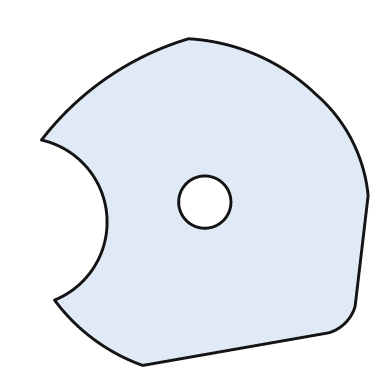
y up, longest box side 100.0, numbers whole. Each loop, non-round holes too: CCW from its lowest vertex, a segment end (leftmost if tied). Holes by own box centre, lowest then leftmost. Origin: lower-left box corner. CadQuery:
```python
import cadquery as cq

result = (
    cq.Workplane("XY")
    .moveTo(31.0, 0.0)
    .lineTo(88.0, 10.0)
    .threePointArc((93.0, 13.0), (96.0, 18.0))
    .lineTo(100.0, 52.0)
    .threePointArc((95.0, 69.0), (84.0, 83.0))
    .threePointArc((66.0, 95.0), (45.0, 100.0))
    .threePointArc((20.0, 88.0), (0.0, 69.0))
    .threePointArc((20.0, 46.0), (4.0, 20.0))
    .threePointArc((16.0, 8.0), (31.0, 0.0))
    .close()
    .moveTo(50.0, 50.0)
    .circle(8.0)
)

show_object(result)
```